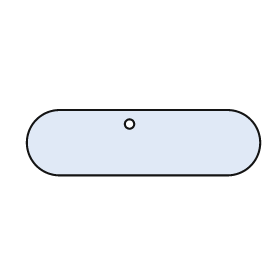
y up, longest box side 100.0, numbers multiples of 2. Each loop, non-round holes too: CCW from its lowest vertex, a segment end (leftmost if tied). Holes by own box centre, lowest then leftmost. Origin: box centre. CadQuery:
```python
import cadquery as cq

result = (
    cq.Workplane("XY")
    .moveTo(-36.0, -14.0)
    .lineTo(36.0, -14.0)
    .threePointArc((50.0, 0.0), (36.0, 14.0))
    .lineTo(-36.0, 14.0)
    .threePointArc((-50.0, 0.0), (-36.0, -14.0))
    .close()
    .moveTo(-6.0, 8.0)
    .circle(2.0)
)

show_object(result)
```